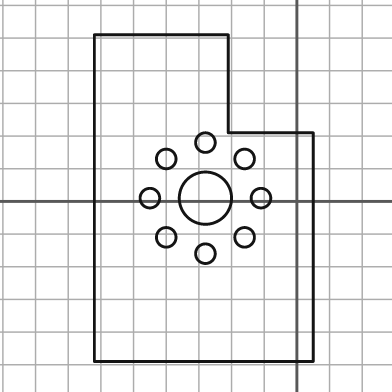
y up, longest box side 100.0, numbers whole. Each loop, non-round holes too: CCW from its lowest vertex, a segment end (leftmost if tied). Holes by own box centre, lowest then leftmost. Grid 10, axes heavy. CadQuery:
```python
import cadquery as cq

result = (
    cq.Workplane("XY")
    .moveTo(-62.0, -49.0)
    .lineTo(5.0, -49.0)
    .lineTo(5.0, 21.0)
    .lineTo(-21.0, 21.0)
    .lineTo(-21.0, 51.0)
    .lineTo(-62.0, 51.0)
    .close()
    .moveTo(-28.0, -16.0)
    .circle(3.0)
    .moveTo(-40.0, -11.0)
    .circle(3.0)
    .moveTo(-16.0, -11.0)
    .circle(3.0)
    .moveTo(-45.0, 1.0)
    .circle(3.0)
    .moveTo(-28.0, 1.0)
    .circle(8.0)
    .moveTo(-11.0, 1.0)
    .circle(3.0)
    .moveTo(-40.0, 13.0)
    .circle(3.0)
    .moveTo(-16.0, 13.0)
    .circle(3.0)
    .moveTo(-28.0, 18.0)
    .circle(3.0)
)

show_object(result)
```